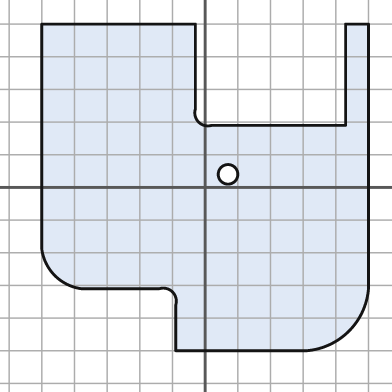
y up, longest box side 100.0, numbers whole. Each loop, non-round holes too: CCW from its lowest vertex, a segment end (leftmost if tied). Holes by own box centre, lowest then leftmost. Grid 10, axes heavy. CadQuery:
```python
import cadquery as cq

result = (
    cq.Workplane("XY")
    .moveTo(-9.0, -50.0)
    .lineTo(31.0, -50.0)
    .threePointArc((44.0, -44.0), (50.0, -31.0))
    .lineTo(50.0, 50.0)
    .lineTo(43.0, 50.0)
    .lineTo(43.0, 19.0)
    .lineTo(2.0, 19.0)
    .threePointArc((-2.0, 20.0), (-3.0, 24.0))
    .lineTo(-3.0, 50.0)
    .lineTo(-50.0, 50.0)
    .lineTo(-50.0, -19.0)
    .threePointArc((-46.0, -27.0), (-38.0, -31.0))
    .lineTo(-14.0, -31.0)
    .threePointArc((-10.0, -32.0), (-9.0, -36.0))
    .close()
    .moveTo(7.0, 4.0)
    .circle(3.0)
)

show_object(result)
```